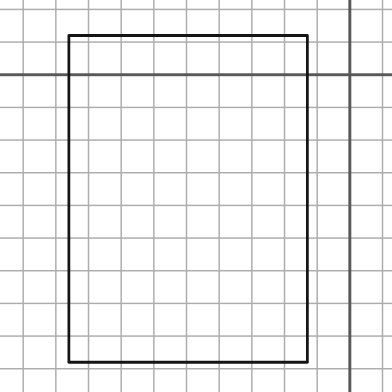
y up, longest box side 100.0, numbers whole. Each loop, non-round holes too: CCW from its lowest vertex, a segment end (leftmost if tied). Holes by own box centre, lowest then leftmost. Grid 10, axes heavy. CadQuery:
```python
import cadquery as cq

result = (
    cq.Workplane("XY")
    .moveTo(-86.0, -88.0)
    .lineTo(-13.0, -88.0)
    .lineTo(-13.0, 12.0)
    .lineTo(-86.0, 12.0)
    .close()
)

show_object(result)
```